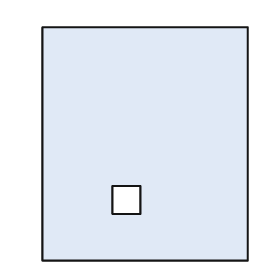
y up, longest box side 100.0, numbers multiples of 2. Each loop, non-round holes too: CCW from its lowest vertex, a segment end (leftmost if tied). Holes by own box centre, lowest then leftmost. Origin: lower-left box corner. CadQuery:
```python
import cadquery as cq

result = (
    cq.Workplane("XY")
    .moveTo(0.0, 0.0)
    .lineTo(88.0, 0.0)
    .lineTo(88.0, 100.0)
    .lineTo(0.0, 100.0)
    .close()
    .moveTo(30.0, 20.0)
    .lineTo(42.0, 20.0)
    .lineTo(42.0, 32.0)
    .lineTo(30.0, 32.0)
    .close()
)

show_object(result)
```